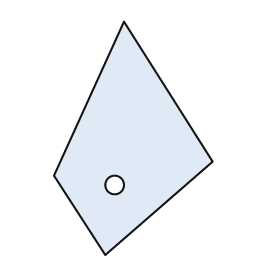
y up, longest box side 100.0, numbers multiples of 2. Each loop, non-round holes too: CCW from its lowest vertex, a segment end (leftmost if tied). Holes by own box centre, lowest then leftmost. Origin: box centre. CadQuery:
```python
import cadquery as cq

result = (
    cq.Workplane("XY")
    .moveTo(-12.0, -50.0)
    .lineTo(34.0, -10.0)
    .lineTo(-4.0, 50.0)
    .lineTo(-34.0, -16.0)
    .close()
    .moveTo(-8.0, -20.0)
    .circle(4.0)
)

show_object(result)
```